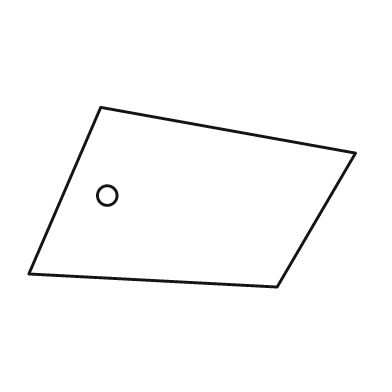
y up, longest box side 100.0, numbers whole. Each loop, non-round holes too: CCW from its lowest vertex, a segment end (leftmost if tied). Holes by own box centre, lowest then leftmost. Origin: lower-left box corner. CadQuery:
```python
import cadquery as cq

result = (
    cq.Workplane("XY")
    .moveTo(76.0, 0.0)
    .lineTo(100.0, 41.0)
    .lineTo(22.0, 55.0)
    .lineTo(0.0, 4.0)
    .close()
    .moveTo(24.0, 28.0)
    .circle(3.0)
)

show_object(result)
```